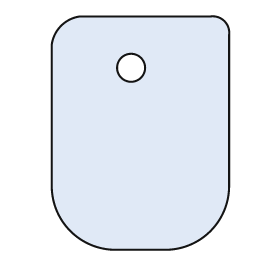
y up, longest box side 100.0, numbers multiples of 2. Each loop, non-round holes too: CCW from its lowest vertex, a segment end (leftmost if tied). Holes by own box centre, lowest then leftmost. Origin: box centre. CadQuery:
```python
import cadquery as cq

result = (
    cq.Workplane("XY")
    .moveTo(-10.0, -50.0)
    .lineTo(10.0, -50.0)
    .threePointArc((30.0, -42.0), (38.0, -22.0))
    .lineTo(38.0, 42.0)
    .threePointArc((36.0, 48.0), (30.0, 50.0))
    .lineTo(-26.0, 50.0)
    .threePointArc((-34.0, 46.0), (-38.0, 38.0))
    .lineTo(-38.0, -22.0)
    .threePointArc((-30.0, -42.0), (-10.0, -50.0))
    .close()
    .moveTo(-4.0, 28.0)
    .circle(6.0)
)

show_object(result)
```